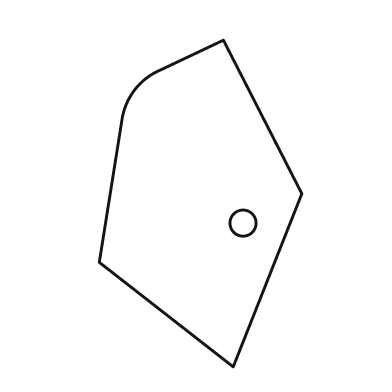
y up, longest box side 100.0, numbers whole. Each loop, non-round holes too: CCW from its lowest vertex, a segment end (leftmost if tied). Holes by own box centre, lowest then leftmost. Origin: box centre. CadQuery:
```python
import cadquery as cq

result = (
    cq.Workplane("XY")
    .moveTo(10.0, -50.0)
    .lineTo(31.0, 3.0)
    .lineTo(7.0, 50.0)
    .lineTo(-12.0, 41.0)
    .threePointArc((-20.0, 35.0), (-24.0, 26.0))
    .lineTo(-31.0, -18.0)
    .close()
    .moveTo(13.0, -6.0)
    .circle(4.0)
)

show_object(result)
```